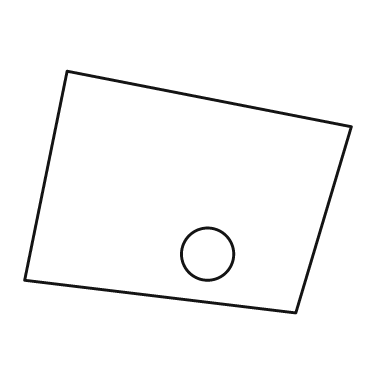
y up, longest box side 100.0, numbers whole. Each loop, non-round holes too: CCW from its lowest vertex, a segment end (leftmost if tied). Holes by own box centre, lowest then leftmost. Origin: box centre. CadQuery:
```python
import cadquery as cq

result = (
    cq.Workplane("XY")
    .moveTo(33.0, -37.0)
    .lineTo(50.0, 20.0)
    .lineTo(-37.0, 37.0)
    .lineTo(-50.0, -27.0)
    .close()
    .moveTo(6.0, -19.0)
    .circle(8.0)
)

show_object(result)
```